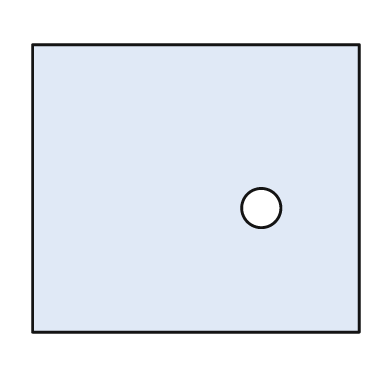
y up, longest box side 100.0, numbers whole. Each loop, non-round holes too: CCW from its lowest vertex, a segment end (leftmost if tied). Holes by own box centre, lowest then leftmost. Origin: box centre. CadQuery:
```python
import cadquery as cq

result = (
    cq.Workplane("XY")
    .moveTo(-50.0, -44.0)
    .lineTo(50.0, -44.0)
    .lineTo(50.0, 44.0)
    .lineTo(-50.0, 44.0)
    .close()
    .moveTo(20.0, -6.0)
    .circle(6.0)
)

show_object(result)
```